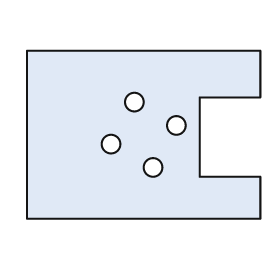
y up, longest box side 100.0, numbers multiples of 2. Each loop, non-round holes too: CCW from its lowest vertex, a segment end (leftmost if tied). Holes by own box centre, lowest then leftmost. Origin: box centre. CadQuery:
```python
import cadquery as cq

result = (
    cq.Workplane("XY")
    .moveTo(-50.0, -36.0)
    .lineTo(50.0, -36.0)
    .lineTo(50.0, -18.0)
    .lineTo(24.0, -18.0)
    .lineTo(24.0, 16.0)
    .lineTo(50.0, 16.0)
    .lineTo(50.0, 36.0)
    .lineTo(-50.0, 36.0)
    .close()
    .moveTo(4.0, -14.0)
    .circle(4.0)
    .moveTo(-14.0, -4.0)
    .circle(4.0)
    .moveTo(14.0, 4.0)
    .circle(4.0)
    .moveTo(-4.0, 14.0)
    .circle(4.0)
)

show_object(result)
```